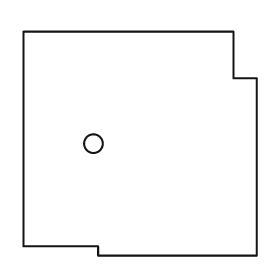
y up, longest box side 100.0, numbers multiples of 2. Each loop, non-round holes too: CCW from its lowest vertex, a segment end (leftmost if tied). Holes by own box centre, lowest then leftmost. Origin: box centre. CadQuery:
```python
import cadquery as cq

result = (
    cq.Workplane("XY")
    .moveTo(-18.0, -48.0)
    .lineTo(50.0, -48.0)
    .lineTo(50.0, 28.0)
    .lineTo(40.0, 28.0)
    .lineTo(40.0, 48.0)
    .lineTo(-50.0, 48.0)
    .lineTo(-50.0, -44.0)
    .lineTo(-18.0, -44.0)
    .close()
    .moveTo(-20.0, 0.0)
    .circle(4.0)
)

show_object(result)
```